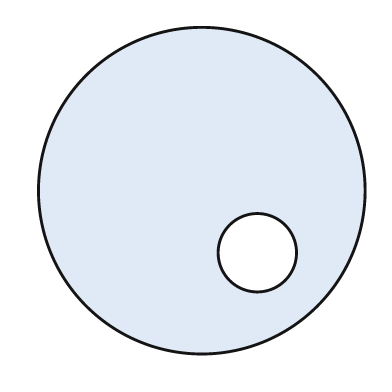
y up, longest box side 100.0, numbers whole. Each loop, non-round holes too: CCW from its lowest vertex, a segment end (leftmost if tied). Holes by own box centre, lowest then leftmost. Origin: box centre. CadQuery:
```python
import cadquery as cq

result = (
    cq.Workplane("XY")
    .moveTo(0.0, 0.0)
    .circle(50.0)
    .moveTo(17.0, -19.0)
    .circle(12.0)
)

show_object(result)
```